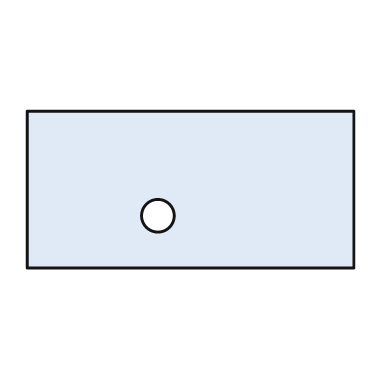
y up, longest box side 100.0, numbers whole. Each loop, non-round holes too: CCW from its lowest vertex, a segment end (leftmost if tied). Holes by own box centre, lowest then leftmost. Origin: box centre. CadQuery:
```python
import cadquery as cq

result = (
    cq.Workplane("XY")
    .moveTo(-50.0, -24.0)
    .lineTo(50.0, -24.0)
    .lineTo(50.0, 24.0)
    .lineTo(-50.0, 24.0)
    .close()
    .moveTo(-10.0, -8.0)
    .circle(5.0)
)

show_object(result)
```